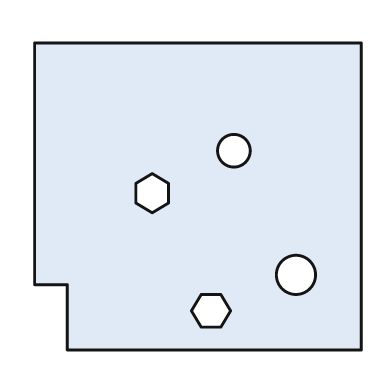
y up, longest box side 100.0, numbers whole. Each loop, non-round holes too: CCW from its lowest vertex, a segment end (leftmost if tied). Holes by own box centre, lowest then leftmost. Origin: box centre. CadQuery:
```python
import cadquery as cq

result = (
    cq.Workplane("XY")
    .moveTo(-40.0, -47.0)
    .lineTo(50.0, -47.0)
    .lineTo(50.0, 47.0)
    .lineTo(-50.0, 47.0)
    .lineTo(-50.0, -27.0)
    .lineTo(-40.0, -27.0)
    .close()
    .moveTo(1.0, -40.0)
    .lineTo(7.0, -40.0)
    .lineTo(10.0, -35.0)
    .lineTo(7.0, -30.0)
    .lineTo(1.0, -30.0)
    .lineTo(-2.0, -35.0)
    .close()
    .moveTo(30.0, -24.0)
    .circle(6.0)
    .moveTo(-14.0, -5.0)
    .lineTo(-9.0, -2.0)
    .lineTo(-9.0, 4.0)
    .lineTo(-14.0, 7.0)
    .lineTo(-19.0, 4.0)
    .lineTo(-19.0, -2.0)
    .close()
    .moveTo(11.0, 14.0)
    .circle(5.0)
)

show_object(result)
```